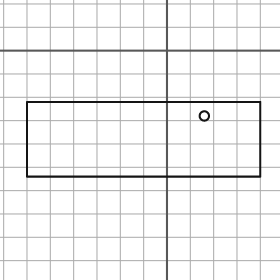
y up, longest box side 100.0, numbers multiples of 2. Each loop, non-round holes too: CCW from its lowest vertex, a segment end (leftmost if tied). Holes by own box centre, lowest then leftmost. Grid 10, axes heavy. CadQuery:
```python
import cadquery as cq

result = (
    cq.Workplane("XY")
    .moveTo(-60.0, -54.0)
    .lineTo(40.0, -54.0)
    .lineTo(40.0, -22.0)
    .lineTo(-60.0, -22.0)
    .close()
    .moveTo(16.0, -28.0)
    .circle(2.0)
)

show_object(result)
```